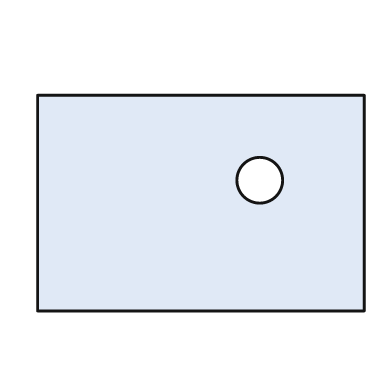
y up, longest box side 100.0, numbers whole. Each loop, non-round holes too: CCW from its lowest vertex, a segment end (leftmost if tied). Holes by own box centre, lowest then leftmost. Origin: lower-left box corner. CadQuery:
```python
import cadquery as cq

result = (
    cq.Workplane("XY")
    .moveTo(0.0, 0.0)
    .lineTo(100.0, 0.0)
    .lineTo(100.0, 66.0)
    .lineTo(0.0, 66.0)
    .close()
    .moveTo(68.0, 40.0)
    .circle(7.0)
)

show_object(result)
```